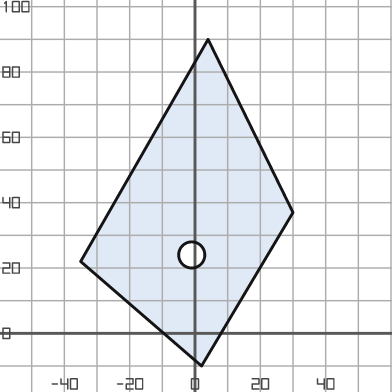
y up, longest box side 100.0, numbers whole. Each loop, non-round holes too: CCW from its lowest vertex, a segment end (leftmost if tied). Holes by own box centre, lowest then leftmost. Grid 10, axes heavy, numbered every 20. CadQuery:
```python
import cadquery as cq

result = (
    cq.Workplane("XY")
    .moveTo(2.0, -10.0)
    .lineTo(30.0, 37.0)
    .lineTo(4.0, 90.0)
    .lineTo(-35.0, 22.0)
    .close()
    .moveTo(-1.0, 24.0)
    .circle(4.0)
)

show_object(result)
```